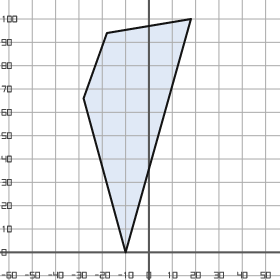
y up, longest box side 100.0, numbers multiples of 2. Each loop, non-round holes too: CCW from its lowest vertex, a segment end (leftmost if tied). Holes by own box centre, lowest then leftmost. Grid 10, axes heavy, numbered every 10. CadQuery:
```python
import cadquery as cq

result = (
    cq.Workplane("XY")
    .moveTo(-10.0, 0.0)
    .lineTo(18.0, 100.0)
    .lineTo(-18.0, 94.0)
    .lineTo(-28.0, 66.0)
    .close()
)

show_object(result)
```